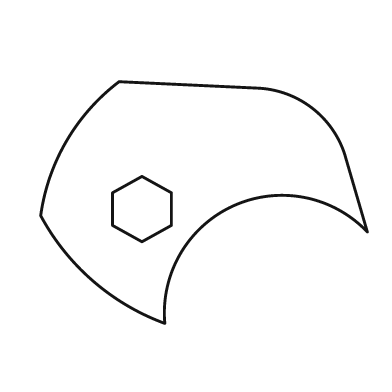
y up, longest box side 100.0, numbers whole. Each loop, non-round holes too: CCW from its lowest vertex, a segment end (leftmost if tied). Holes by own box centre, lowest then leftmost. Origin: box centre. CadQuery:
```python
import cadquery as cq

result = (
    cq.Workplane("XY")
    .moveTo(-12.0, -37.0)
    .threePointArc((9.0, -1.0), (50.0, -9.0))
    .lineTo(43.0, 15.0)
    .threePointArc((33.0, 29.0), (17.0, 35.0))
    .lineTo(-26.0, 37.0)
    .threePointArc((-42.0, 19.0), (-50.0, -4.0))
    .threePointArc((-34.0, -24.0), (-12.0, -37.0))
    .close()
    .moveTo(-19.0, -12.0)
    .lineTo(-10.0, -7.0)
    .lineTo(-10.0, 3.0)
    .lineTo(-19.0, 8.0)
    .lineTo(-28.0, 3.0)
    .lineTo(-28.0, -7.0)
    .close()
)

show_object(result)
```